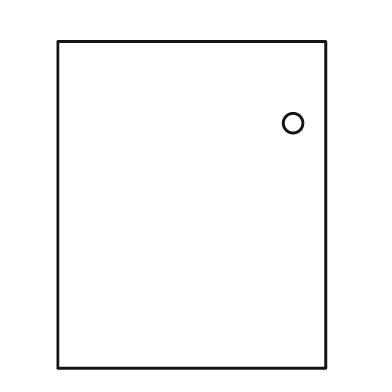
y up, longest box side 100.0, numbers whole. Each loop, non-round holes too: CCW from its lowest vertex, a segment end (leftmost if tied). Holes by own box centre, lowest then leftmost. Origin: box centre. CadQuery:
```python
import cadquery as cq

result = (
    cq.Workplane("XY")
    .moveTo(-41.0, -50.0)
    .lineTo(41.0, -50.0)
    .lineTo(41.0, 50.0)
    .lineTo(-41.0, 50.0)
    .close()
    .moveTo(31.0, 25.0)
    .circle(3.0)
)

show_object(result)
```